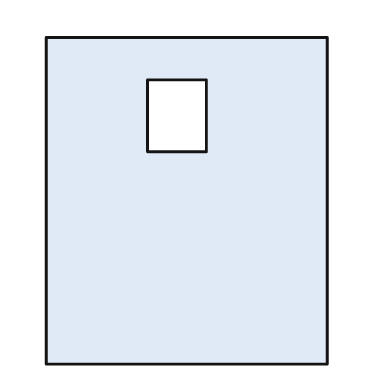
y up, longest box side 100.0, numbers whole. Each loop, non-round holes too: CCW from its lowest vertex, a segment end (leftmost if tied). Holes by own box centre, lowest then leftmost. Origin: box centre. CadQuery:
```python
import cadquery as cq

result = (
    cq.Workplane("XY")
    .moveTo(-43.0, -50.0)
    .lineTo(43.0, -50.0)
    .lineTo(43.0, 50.0)
    .lineTo(-43.0, 50.0)
    .close()
    .moveTo(-12.0, 15.0)
    .lineTo(6.0, 15.0)
    .lineTo(6.0, 37.0)
    .lineTo(-12.0, 37.0)
    .close()
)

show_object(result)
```